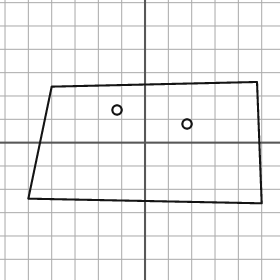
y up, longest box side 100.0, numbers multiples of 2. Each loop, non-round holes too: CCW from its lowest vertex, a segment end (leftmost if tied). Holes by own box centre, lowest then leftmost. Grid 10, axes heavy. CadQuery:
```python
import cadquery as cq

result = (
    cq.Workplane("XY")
    .moveTo(50.0, -26.0)
    .lineTo(48.0, 26.0)
    .lineTo(-40.0, 24.0)
    .lineTo(-50.0, -24.0)
    .close()
    .moveTo(18.0, 8.0)
    .circle(2.0)
    .moveTo(-12.0, 14.0)
    .circle(2.0)
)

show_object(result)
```